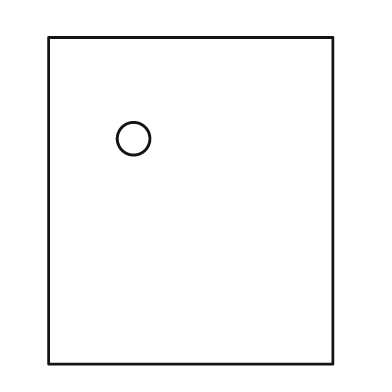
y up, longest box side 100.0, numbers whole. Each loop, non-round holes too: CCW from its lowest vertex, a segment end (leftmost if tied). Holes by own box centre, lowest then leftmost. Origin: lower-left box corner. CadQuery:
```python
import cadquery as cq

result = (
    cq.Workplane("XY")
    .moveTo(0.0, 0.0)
    .lineTo(87.0, 0.0)
    .lineTo(87.0, 100.0)
    .lineTo(0.0, 100.0)
    .close()
    .moveTo(26.0, 69.0)
    .circle(5.0)
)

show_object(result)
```